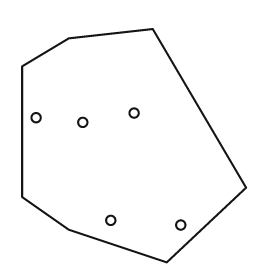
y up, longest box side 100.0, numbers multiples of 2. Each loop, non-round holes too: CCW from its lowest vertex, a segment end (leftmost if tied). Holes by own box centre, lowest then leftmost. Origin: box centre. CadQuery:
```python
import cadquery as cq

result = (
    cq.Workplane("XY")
    .moveTo(14.0, -50.0)
    .lineTo(48.0, -18.0)
    .lineTo(8.0, 50.0)
    .lineTo(-28.0, 46.0)
    .lineTo(-48.0, 34.0)
    .lineTo(-48.0, -22.0)
    .lineTo(-28.0, -36.0)
    .close()
    .moveTo(20.0, -34.0)
    .circle(2.0)
    .moveTo(-10.0, -32.0)
    .circle(2.0)
    .moveTo(-22.0, 10.0)
    .circle(2.0)
    .moveTo(-42.0, 12.0)
    .circle(2.0)
    .moveTo(0.0, 14.0)
    .circle(2.0)
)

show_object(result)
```